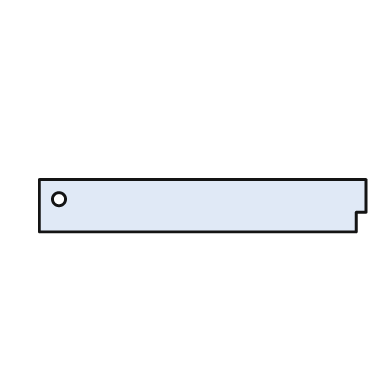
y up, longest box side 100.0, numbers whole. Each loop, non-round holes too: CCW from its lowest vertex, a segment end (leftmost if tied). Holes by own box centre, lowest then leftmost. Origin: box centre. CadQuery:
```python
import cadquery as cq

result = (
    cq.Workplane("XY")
    .moveTo(-50.0, -8.0)
    .lineTo(47.0, -8.0)
    .lineTo(47.0, -2.0)
    .lineTo(50.0, -2.0)
    .lineTo(50.0, 8.0)
    .lineTo(-50.0, 8.0)
    .close()
    .moveTo(-44.0, 2.0)
    .circle(2.0)
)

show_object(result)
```